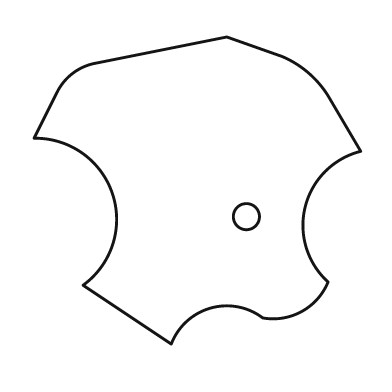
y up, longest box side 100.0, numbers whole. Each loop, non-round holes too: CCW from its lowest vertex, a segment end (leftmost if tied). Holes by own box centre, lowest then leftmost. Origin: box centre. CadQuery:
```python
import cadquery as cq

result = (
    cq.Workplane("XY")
    .moveTo(-8.0, -47.0)
    .threePointArc((4.0, -36.0), (20.0, -39.0))
    .threePointArc((32.0, -37.0), (40.0, -28.0))
    .threePointArc((33.0, -5.0), (50.0, 12.0))
    .lineTo(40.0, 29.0)
    .threePointArc((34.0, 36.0), (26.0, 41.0))
    .lineTo(9.0, 47.0)
    .lineTo(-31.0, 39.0)
    .threePointArc((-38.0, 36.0), (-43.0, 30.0))
    .lineTo(-50.0, 16.0)
    .threePointArc((-26.0, -1.0), (-35.0, -29.0))
    .close()
    .moveTo(15.0, -8.0)
    .circle(4.0)
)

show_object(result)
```